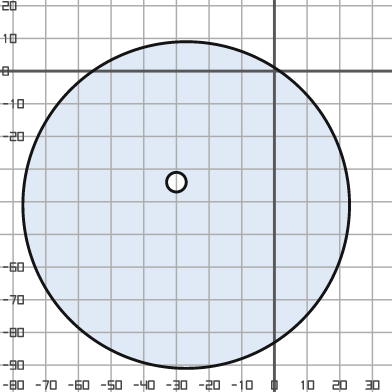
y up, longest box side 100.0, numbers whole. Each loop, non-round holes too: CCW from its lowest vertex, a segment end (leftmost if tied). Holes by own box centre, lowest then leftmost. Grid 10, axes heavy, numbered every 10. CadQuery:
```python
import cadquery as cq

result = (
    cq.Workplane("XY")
    .moveTo(-27.0, -41.0)
    .circle(50.0)
    .moveTo(-30.0, -34.0)
    .circle(3.0)
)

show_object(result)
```